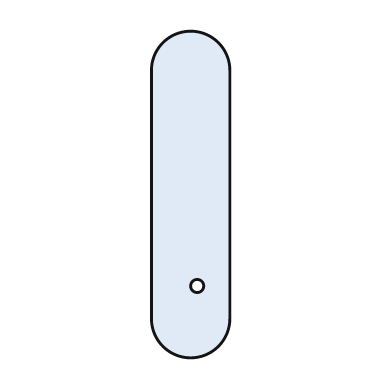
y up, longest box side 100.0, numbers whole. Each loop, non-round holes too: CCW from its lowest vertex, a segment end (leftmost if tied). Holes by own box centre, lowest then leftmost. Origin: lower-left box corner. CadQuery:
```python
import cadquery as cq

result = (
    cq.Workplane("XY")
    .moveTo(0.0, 12.0)
    .threePointArc((12.0, 0.0), (24.0, 12.0))
    .lineTo(24.0, 88.0)
    .threePointArc((12.0, 100.0), (0.0, 88.0))
    .close()
    .moveTo(14.0, 22.0)
    .circle(2.0)
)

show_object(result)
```